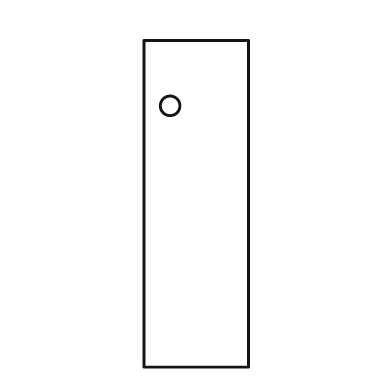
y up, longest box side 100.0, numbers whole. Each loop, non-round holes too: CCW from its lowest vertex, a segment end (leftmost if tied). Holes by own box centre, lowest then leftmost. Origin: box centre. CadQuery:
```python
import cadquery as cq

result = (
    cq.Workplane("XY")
    .moveTo(-16.0, -50.0)
    .lineTo(16.0, -50.0)
    .lineTo(16.0, 50.0)
    .lineTo(-16.0, 50.0)
    .close()
    .moveTo(-8.0, 30.0)
    .circle(3.0)
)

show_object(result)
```